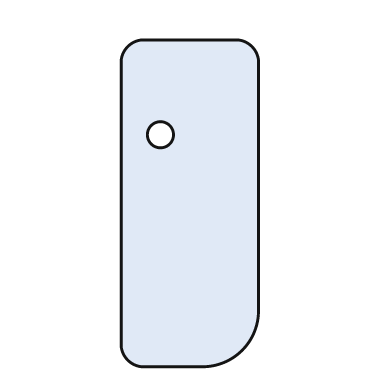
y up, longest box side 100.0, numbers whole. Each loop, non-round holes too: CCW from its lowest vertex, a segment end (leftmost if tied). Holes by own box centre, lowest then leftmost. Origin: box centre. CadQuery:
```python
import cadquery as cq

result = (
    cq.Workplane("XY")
    .moveTo(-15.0, -50.0)
    .lineTo(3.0, -50.0)
    .threePointArc((16.0, -45.0), (21.0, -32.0))
    .lineTo(21.0, 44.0)
    .threePointArc((19.0, 48.0), (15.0, 50.0))
    .lineTo(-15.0, 50.0)
    .threePointArc((-19.0, 48.0), (-21.0, 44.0))
    .lineTo(-21.0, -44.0)
    .threePointArc((-19.0, -48.0), (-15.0, -50.0))
    .close()
    .moveTo(-9.0, 21.0)
    .circle(4.0)
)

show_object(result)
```